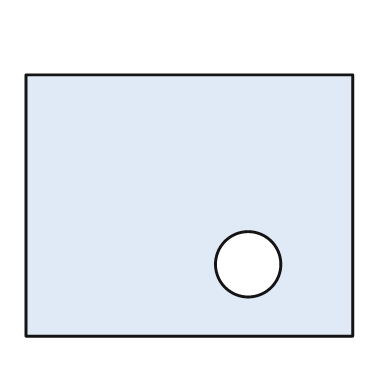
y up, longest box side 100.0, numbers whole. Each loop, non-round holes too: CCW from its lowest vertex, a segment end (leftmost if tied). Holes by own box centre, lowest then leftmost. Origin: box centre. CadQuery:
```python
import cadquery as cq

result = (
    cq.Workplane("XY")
    .moveTo(-50.0, -40.0)
    .lineTo(50.0, -40.0)
    .lineTo(50.0, 40.0)
    .lineTo(-50.0, 40.0)
    .close()
    .moveTo(18.0, -18.0)
    .circle(10.0)
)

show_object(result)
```